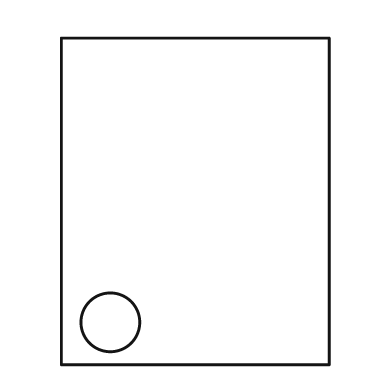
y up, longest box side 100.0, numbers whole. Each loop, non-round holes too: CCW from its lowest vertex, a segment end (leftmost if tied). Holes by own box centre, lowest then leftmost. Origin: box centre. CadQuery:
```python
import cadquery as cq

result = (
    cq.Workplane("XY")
    .moveTo(-41.0, -50.0)
    .lineTo(41.0, -50.0)
    .lineTo(41.0, 50.0)
    .lineTo(-41.0, 50.0)
    .close()
    .moveTo(-26.0, -37.0)
    .circle(9.0)
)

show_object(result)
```